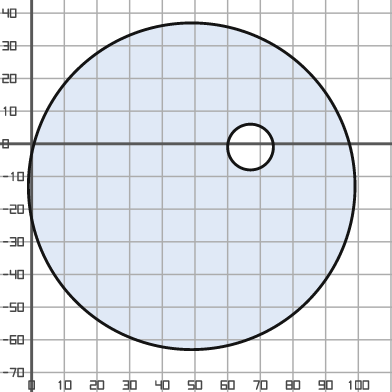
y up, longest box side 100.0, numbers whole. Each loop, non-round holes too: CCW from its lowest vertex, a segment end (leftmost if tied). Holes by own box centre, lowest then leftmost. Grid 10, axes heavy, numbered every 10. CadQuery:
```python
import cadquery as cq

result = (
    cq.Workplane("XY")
    .moveTo(49.0, -13.0)
    .circle(50.0)
    .moveTo(67.0, -1.0)
    .circle(7.0)
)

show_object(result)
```